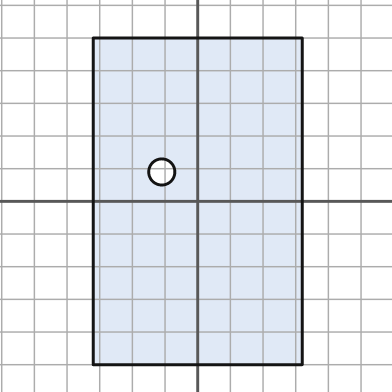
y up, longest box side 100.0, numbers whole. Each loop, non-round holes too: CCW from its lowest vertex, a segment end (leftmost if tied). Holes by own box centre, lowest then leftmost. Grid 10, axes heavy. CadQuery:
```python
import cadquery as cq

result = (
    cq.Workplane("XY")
    .moveTo(-32.0, -50.0)
    .lineTo(32.0, -50.0)
    .lineTo(32.0, 50.0)
    .lineTo(-32.0, 50.0)
    .close()
    .moveTo(-11.0, 9.0)
    .circle(4.0)
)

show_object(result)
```